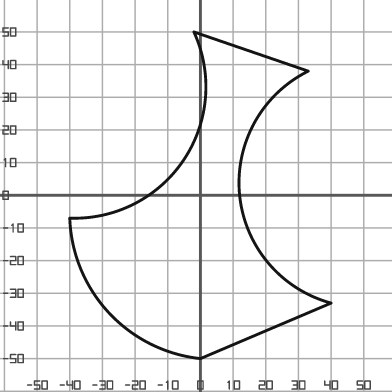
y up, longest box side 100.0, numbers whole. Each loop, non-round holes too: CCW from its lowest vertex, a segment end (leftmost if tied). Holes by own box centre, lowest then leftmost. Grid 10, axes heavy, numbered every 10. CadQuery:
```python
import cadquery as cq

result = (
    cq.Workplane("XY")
    .moveTo(0.0, -50.0)
    .lineTo(40.0, -33.0)
    .threePointArc((12.0, 0.0), (33.0, 38.0))
    .lineTo(-2.0, 50.0)
    .threePointArc((-5.0, 11.0), (-40.0, -7.0))
    .threePointArc((-28.0, -36.0), (0.0, -50.0))
    .close()
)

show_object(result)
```